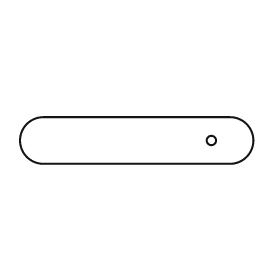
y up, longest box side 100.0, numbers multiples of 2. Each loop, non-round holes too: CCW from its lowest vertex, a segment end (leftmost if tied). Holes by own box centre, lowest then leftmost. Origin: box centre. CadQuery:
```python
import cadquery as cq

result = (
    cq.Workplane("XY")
    .moveTo(-40.0, -10.0)
    .lineTo(40.0, -10.0)
    .threePointArc((50.0, 0.0), (40.0, 10.0))
    .lineTo(-40.0, 10.0)
    .threePointArc((-50.0, 0.0), (-40.0, -10.0))
    .close()
    .moveTo(32.0, 0.0)
    .circle(2.0)
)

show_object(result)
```